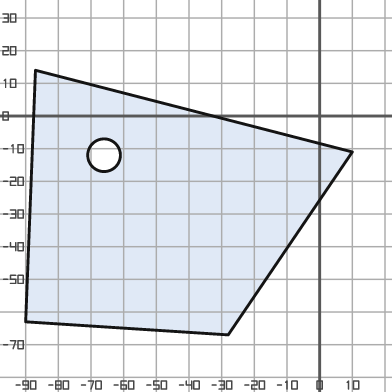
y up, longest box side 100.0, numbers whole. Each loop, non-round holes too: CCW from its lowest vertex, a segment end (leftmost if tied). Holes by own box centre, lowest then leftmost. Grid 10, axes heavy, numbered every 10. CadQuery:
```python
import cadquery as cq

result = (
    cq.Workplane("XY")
    .moveTo(-28.0, -67.0)
    .lineTo(10.0, -11.0)
    .lineTo(-87.0, 14.0)
    .lineTo(-90.0, -63.0)
    .close()
    .moveTo(-66.0, -12.0)
    .circle(5.0)
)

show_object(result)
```